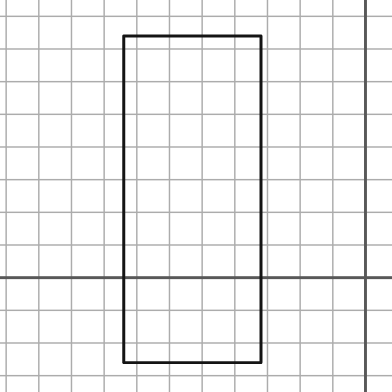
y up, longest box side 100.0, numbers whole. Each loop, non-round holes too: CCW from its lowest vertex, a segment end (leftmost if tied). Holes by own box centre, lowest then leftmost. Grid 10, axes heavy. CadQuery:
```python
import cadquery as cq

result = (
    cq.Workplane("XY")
    .moveTo(-74.0, -26.0)
    .lineTo(-32.0, -26.0)
    .lineTo(-32.0, 74.0)
    .lineTo(-74.0, 74.0)
    .close()
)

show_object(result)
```